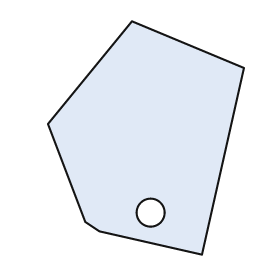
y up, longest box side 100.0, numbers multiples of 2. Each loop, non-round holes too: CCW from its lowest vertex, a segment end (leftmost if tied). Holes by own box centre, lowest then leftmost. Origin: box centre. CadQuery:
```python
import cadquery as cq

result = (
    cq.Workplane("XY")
    .moveTo(24.0, -50.0)
    .lineTo(42.0, 30.0)
    .lineTo(-6.0, 50.0)
    .lineTo(-42.0, 6.0)
    .lineTo(-26.0, -36.0)
    .lineTo(-20.0, -40.0)
    .close()
    .moveTo(2.0, -32.0)
    .circle(6.0)
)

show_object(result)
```